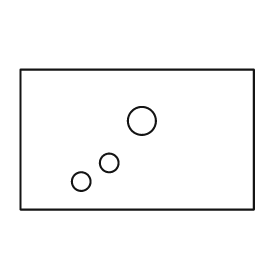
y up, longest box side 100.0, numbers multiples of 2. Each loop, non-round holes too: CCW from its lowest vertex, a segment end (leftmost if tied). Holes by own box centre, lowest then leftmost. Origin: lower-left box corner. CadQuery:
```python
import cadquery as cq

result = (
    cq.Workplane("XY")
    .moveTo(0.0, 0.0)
    .lineTo(100.0, 0.0)
    .lineTo(100.0, 60.0)
    .lineTo(0.0, 60.0)
    .close()
    .moveTo(26.0, 12.0)
    .circle(4.0)
    .moveTo(38.0, 20.0)
    .circle(4.0)
    .moveTo(52.0, 38.0)
    .circle(6.0)
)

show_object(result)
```